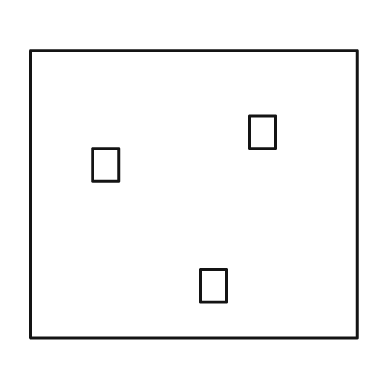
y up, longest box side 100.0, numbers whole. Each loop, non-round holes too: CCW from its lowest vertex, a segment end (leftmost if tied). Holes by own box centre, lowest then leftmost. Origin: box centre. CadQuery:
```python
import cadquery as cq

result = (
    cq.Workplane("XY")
    .moveTo(-50.0, -44.0)
    .lineTo(50.0, -44.0)
    .lineTo(50.0, 44.0)
    .lineTo(-50.0, 44.0)
    .close()
    .moveTo(2.0, -33.0)
    .lineTo(10.0, -33.0)
    .lineTo(10.0, -23.0)
    .lineTo(2.0, -23.0)
    .close()
    .moveTo(-31.0, 4.0)
    .lineTo(-23.0, 4.0)
    .lineTo(-23.0, 14.0)
    .lineTo(-31.0, 14.0)
    .close()
    .moveTo(17.0, 14.0)
    .lineTo(25.0, 14.0)
    .lineTo(25.0, 24.0)
    .lineTo(17.0, 24.0)
    .close()
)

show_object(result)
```